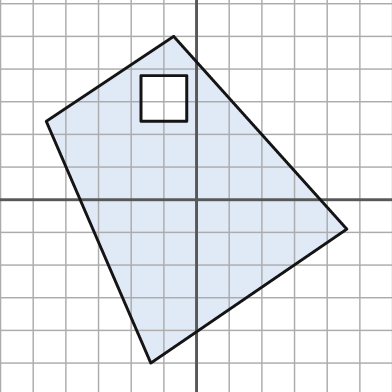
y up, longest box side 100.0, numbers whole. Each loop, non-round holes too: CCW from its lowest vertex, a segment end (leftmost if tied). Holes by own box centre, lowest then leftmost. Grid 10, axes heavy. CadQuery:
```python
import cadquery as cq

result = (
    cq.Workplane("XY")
    .moveTo(-14.0, -50.0)
    .lineTo(46.0, -9.0)
    .lineTo(-7.0, 50.0)
    .lineTo(-46.0, 24.0)
    .close()
    .moveTo(-17.0, 24.0)
    .lineTo(-3.0, 24.0)
    .lineTo(-3.0, 38.0)
    .lineTo(-17.0, 38.0)
    .close()
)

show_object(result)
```